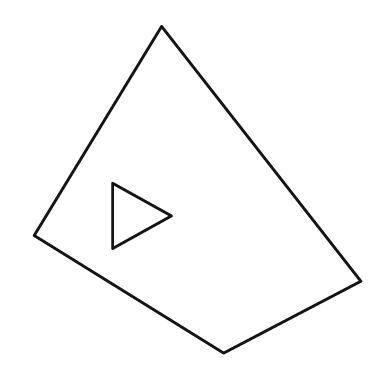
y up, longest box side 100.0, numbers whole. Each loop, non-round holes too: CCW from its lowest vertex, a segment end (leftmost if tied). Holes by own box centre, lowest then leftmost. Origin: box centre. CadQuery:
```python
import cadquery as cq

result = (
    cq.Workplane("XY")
    .moveTo(8.0, -50.0)
    .lineTo(50.0, -28.0)
    .lineTo(-11.0, 50.0)
    .lineTo(-50.0, -14.0)
    .close()
    .moveTo(-26.0, -18.0)
    .lineTo(-8.0, -8.0)
    .lineTo(-26.0, 2.0)
    .close()
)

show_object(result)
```